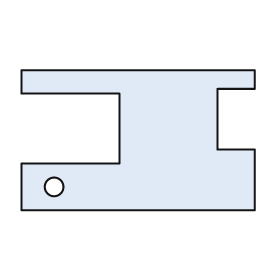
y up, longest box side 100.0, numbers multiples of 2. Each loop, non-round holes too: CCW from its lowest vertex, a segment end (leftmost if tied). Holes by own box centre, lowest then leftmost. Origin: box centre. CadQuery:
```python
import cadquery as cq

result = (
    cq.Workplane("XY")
    .moveTo(-50.0, -30.0)
    .lineTo(50.0, -30.0)
    .lineTo(50.0, -4.0)
    .lineTo(34.0, -4.0)
    .lineTo(34.0, 22.0)
    .lineTo(50.0, 22.0)
    .lineTo(50.0, 30.0)
    .lineTo(-50.0, 30.0)
    .lineTo(-50.0, 20.0)
    .lineTo(-8.0, 20.0)
    .lineTo(-8.0, -10.0)
    .lineTo(-50.0, -10.0)
    .close()
    .moveTo(-36.0, -20.0)
    .circle(4.0)
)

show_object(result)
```